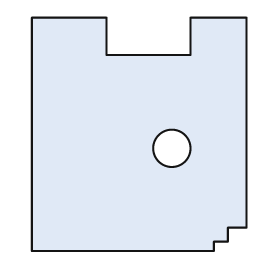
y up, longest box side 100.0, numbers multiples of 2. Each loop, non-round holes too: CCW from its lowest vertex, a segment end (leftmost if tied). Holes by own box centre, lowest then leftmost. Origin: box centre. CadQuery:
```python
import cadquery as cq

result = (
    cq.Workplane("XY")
    .moveTo(-46.0, -50.0)
    .lineTo(32.0, -50.0)
    .lineTo(32.0, -46.0)
    .lineTo(38.0, -46.0)
    .lineTo(38.0, -40.0)
    .lineTo(46.0, -40.0)
    .lineTo(46.0, 50.0)
    .lineTo(22.0, 50.0)
    .lineTo(22.0, 34.0)
    .lineTo(-14.0, 34.0)
    .lineTo(-14.0, 50.0)
    .lineTo(-46.0, 50.0)
    .close()
    .moveTo(14.0, -6.0)
    .circle(8.0)
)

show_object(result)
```